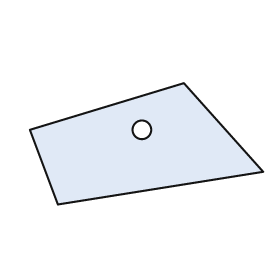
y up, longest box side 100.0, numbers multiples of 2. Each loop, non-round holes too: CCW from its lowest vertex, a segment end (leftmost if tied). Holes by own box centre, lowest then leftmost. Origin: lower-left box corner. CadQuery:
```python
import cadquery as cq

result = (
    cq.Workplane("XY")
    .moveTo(12.0, 0.0)
    .lineTo(100.0, 14.0)
    .lineTo(66.0, 52.0)
    .lineTo(0.0, 32.0)
    .close()
    .moveTo(48.0, 32.0)
    .circle(4.0)
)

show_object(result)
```